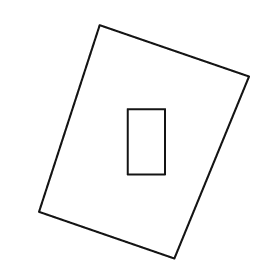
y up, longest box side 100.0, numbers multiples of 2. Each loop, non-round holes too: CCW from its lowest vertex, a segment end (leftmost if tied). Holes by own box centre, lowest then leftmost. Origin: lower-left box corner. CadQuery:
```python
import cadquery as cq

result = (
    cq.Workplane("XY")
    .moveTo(58.0, 0.0)
    .lineTo(90.0, 78.0)
    .lineTo(26.0, 100.0)
    .lineTo(0.0, 20.0)
    .close()
    .moveTo(38.0, 36.0)
    .lineTo(54.0, 36.0)
    .lineTo(54.0, 64.0)
    .lineTo(38.0, 64.0)
    .close()
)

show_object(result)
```